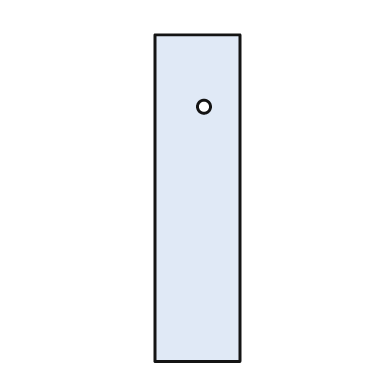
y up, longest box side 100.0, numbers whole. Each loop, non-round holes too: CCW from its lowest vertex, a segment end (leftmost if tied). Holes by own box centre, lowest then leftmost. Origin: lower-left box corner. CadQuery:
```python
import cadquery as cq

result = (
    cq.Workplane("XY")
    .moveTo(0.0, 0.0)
    .lineTo(26.0, 0.0)
    .lineTo(26.0, 100.0)
    .lineTo(0.0, 100.0)
    .close()
    .moveTo(15.0, 78.0)
    .circle(2.0)
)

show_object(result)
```